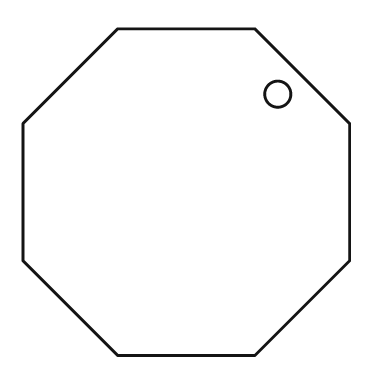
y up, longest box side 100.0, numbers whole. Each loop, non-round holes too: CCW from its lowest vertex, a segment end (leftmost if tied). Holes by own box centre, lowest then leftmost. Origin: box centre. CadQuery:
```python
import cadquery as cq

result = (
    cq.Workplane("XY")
    .moveTo(-21.0, -50.0)
    .lineTo(21.0, -50.0)
    .lineTo(50.0, -21.0)
    .lineTo(50.0, 21.0)
    .lineTo(21.0, 50.0)
    .lineTo(-21.0, 50.0)
    .lineTo(-50.0, 21.0)
    .lineTo(-50.0, -21.0)
    .close()
    .moveTo(28.0, 30.0)
    .circle(4.0)
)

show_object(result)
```